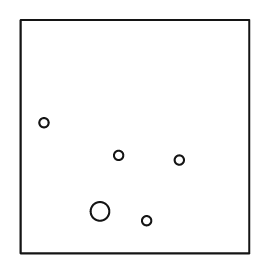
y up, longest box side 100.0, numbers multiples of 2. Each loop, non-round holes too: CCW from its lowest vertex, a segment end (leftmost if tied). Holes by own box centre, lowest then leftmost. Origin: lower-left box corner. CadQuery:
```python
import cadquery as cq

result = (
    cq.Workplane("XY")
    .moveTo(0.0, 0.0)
    .lineTo(98.0, 0.0)
    .lineTo(98.0, 100.0)
    .lineTo(0.0, 100.0)
    .close()
    .moveTo(54.0, 14.0)
    .circle(2.0)
    .moveTo(34.0, 18.0)
    .circle(4.0)
    .moveTo(68.0, 40.0)
    .circle(2.0)
    .moveTo(42.0, 42.0)
    .circle(2.0)
    .moveTo(10.0, 56.0)
    .circle(2.0)
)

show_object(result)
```